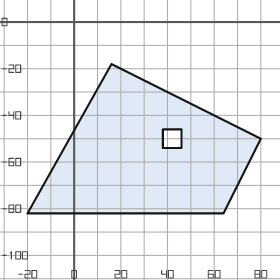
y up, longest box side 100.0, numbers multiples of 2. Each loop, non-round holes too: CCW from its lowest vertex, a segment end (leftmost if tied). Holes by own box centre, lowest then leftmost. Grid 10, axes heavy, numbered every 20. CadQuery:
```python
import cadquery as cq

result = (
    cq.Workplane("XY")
    .moveTo(-20.0, -82.0)
    .lineTo(64.0, -82.0)
    .lineTo(80.0, -50.0)
    .lineTo(16.0, -18.0)
    .close()
    .moveTo(38.0, -54.0)
    .lineTo(46.0, -54.0)
    .lineTo(46.0, -46.0)
    .lineTo(38.0, -46.0)
    .close()
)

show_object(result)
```